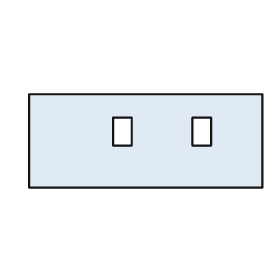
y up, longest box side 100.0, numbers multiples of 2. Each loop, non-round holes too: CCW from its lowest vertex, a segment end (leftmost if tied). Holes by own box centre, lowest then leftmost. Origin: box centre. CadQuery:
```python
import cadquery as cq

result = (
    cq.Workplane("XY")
    .moveTo(-50.0, -20.0)
    .lineTo(50.0, -20.0)
    .lineTo(50.0, 20.0)
    .lineTo(-50.0, 20.0)
    .close()
    .moveTo(-14.0, -2.0)
    .lineTo(-6.0, -2.0)
    .lineTo(-6.0, 10.0)
    .lineTo(-14.0, 10.0)
    .close()
    .moveTo(20.0, -2.0)
    .lineTo(28.0, -2.0)
    .lineTo(28.0, 10.0)
    .lineTo(20.0, 10.0)
    .close()
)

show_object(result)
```